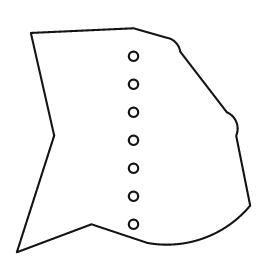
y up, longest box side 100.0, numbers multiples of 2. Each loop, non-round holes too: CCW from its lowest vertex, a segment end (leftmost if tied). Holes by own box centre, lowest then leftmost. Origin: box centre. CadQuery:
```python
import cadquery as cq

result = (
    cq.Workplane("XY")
    .moveTo(-50.0, -48.0)
    .lineTo(-18.0, -36.0)
    .lineTo(6.0, -44.0)
    .threePointArc((30.0, -42.0), (50.0, -28.0))
    .lineTo(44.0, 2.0)
    .threePointArc((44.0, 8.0), (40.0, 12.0))
    .lineTo(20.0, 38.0)
    .threePointArc((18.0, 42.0), (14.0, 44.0))
    .lineTo(0.0, 48.0)
    .lineTo(-44.0, 46.0)
    .lineTo(-34.0, 2.0)
    .close()
    .moveTo(0.0, -36.0)
    .circle(2.0)
    .moveTo(0.0, -24.0)
    .circle(2.0)
    .moveTo(0.0, -12.0)
    .circle(2.0)
    .moveTo(0.0, 0.0)
    .circle(2.0)
    .moveTo(0.0, 12.0)
    .circle(2.0)
    .moveTo(0.0, 24.0)
    .circle(2.0)
    .moveTo(0.0, 36.0)
    .circle(2.0)
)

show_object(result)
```